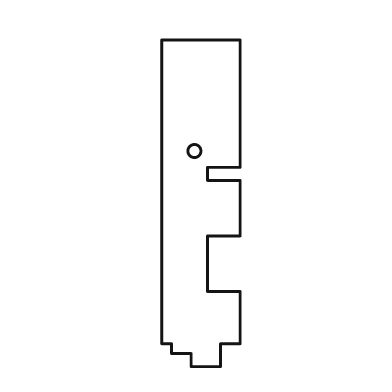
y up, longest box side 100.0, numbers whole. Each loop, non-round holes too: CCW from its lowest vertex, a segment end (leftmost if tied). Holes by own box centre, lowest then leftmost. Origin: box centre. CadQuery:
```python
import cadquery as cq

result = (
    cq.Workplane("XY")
    .moveTo(-3.0, -50.0)
    .lineTo(6.0, -50.0)
    .lineTo(6.0, -43.0)
    .lineTo(12.0, -43.0)
    .lineTo(12.0, -27.0)
    .lineTo(2.0, -27.0)
    .lineTo(2.0, -10.0)
    .lineTo(12.0, -10.0)
    .lineTo(12.0, 7.0)
    .lineTo(2.0, 7.0)
    .lineTo(2.0, 11.0)
    .lineTo(12.0, 11.0)
    .lineTo(12.0, 50.0)
    .lineTo(-12.0, 50.0)
    .lineTo(-12.0, -43.0)
    .lineTo(-9.0, -43.0)
    .lineTo(-9.0, -46.0)
    .lineTo(-3.0, -46.0)
    .close()
    .moveTo(-2.0, 16.0)
    .circle(2.0)
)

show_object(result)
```